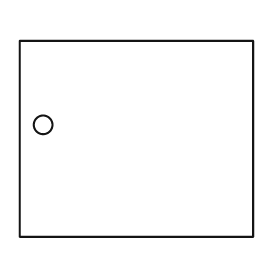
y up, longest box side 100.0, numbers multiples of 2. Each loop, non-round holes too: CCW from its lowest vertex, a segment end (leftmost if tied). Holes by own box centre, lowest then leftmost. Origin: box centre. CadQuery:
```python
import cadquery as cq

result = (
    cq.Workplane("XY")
    .moveTo(-50.0, -42.0)
    .lineTo(50.0, -42.0)
    .lineTo(50.0, 42.0)
    .lineTo(-50.0, 42.0)
    .close()
    .moveTo(-40.0, 6.0)
    .circle(4.0)
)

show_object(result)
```